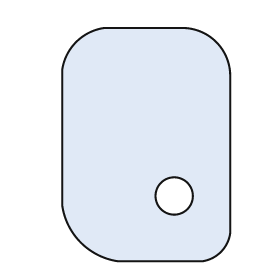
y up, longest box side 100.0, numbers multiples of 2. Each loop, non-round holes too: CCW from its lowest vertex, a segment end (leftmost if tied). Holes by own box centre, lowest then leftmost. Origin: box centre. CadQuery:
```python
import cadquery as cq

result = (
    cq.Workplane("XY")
    .moveTo(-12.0, -50.0)
    .lineTo(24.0, -50.0)
    .threePointArc((32.0, -46.0), (36.0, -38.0))
    .lineTo(36.0, 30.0)
    .threePointArc((30.0, 44.0), (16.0, 50.0))
    .lineTo(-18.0, 50.0)
    .threePointArc((-30.0, 44.0), (-36.0, 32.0))
    .lineTo(-36.0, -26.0)
    .threePointArc((-28.0, -42.0), (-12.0, -50.0))
    .close()
    .moveTo(12.0, -22.0)
    .circle(8.0)
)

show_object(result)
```